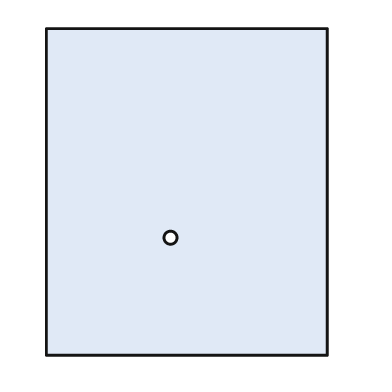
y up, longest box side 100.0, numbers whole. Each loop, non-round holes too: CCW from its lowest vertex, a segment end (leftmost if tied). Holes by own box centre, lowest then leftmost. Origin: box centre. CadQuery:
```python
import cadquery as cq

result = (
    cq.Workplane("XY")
    .moveTo(-43.0, -50.0)
    .lineTo(43.0, -50.0)
    .lineTo(43.0, 50.0)
    .lineTo(-43.0, 50.0)
    .close()
    .moveTo(-5.0, -14.0)
    .circle(2.0)
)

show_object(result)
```